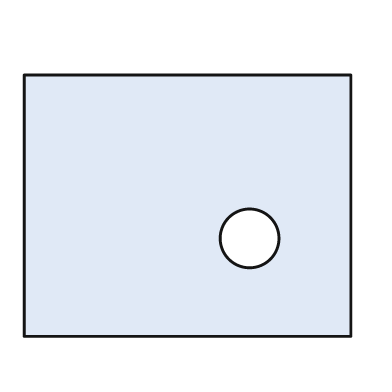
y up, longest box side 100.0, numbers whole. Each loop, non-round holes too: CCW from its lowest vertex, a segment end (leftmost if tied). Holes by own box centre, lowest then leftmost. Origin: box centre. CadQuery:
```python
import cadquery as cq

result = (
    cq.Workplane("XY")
    .moveTo(-50.0, -40.0)
    .lineTo(50.0, -40.0)
    .lineTo(50.0, 40.0)
    .lineTo(-50.0, 40.0)
    .close()
    .moveTo(19.0, -10.0)
    .circle(9.0)
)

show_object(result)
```